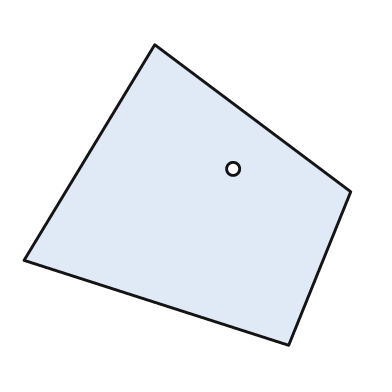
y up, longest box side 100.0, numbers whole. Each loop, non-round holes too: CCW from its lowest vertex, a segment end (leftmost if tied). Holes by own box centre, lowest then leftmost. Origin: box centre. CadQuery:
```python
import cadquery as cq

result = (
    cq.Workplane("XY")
    .moveTo(31.0, -46.0)
    .lineTo(50.0, 1.0)
    .lineTo(-10.0, 46.0)
    .lineTo(-50.0, -20.0)
    .close()
    .moveTo(14.0, 8.0)
    .circle(2.0)
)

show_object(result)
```